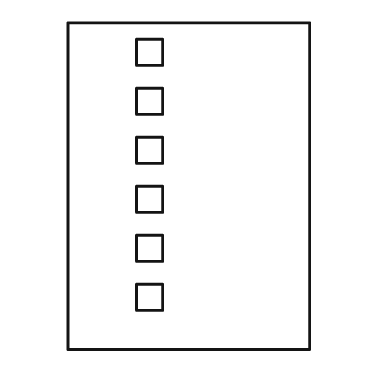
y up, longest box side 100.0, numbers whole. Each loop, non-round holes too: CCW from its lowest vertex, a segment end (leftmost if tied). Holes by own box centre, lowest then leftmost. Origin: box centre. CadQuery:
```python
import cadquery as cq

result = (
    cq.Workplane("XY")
    .moveTo(-37.0, -50.0)
    .lineTo(37.0, -50.0)
    .lineTo(37.0, 50.0)
    .lineTo(-37.0, 50.0)
    .close()
    .moveTo(-16.0, -38.0)
    .lineTo(-8.0, -38.0)
    .lineTo(-8.0, -30.0)
    .lineTo(-16.0, -30.0)
    .close()
    .moveTo(-16.0, -23.0)
    .lineTo(-8.0, -23.0)
    .lineTo(-8.0, -15.0)
    .lineTo(-16.0, -15.0)
    .close()
    .moveTo(-16.0, -8.0)
    .lineTo(-8.0, -8.0)
    .lineTo(-8.0, 0.0)
    .lineTo(-16.0, 0.0)
    .close()
    .moveTo(-16.0, 7.0)
    .lineTo(-8.0, 7.0)
    .lineTo(-8.0, 15.0)
    .lineTo(-16.0, 15.0)
    .close()
    .moveTo(-16.0, 22.0)
    .lineTo(-8.0, 22.0)
    .lineTo(-8.0, 30.0)
    .lineTo(-16.0, 30.0)
    .close()
    .moveTo(-16.0, 37.0)
    .lineTo(-8.0, 37.0)
    .lineTo(-8.0, 45.0)
    .lineTo(-16.0, 45.0)
    .close()
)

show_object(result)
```